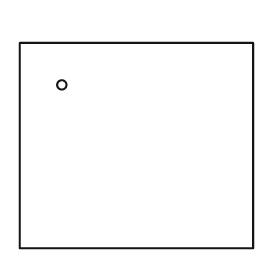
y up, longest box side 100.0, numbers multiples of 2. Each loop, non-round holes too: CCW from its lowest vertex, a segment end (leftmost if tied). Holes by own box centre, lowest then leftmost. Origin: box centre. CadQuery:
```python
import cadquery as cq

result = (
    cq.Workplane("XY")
    .moveTo(-50.0, -44.0)
    .lineTo(50.0, -44.0)
    .lineTo(50.0, 44.0)
    .lineTo(-50.0, 44.0)
    .close()
    .moveTo(-32.0, 26.0)
    .circle(2.0)
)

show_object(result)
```